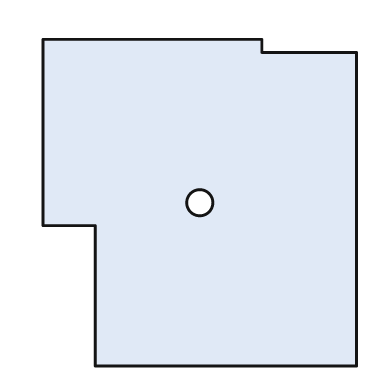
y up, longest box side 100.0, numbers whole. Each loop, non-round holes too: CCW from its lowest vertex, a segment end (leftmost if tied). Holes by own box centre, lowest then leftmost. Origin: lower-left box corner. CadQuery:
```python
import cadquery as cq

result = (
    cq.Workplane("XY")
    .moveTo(16.0, 0.0)
    .lineTo(96.0, 0.0)
    .lineTo(96.0, 96.0)
    .lineTo(67.0, 96.0)
    .lineTo(67.0, 100.0)
    .lineTo(0.0, 100.0)
    .lineTo(0.0, 43.0)
    .lineTo(16.0, 43.0)
    .close()
    .moveTo(48.0, 50.0)
    .circle(4.0)
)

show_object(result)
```